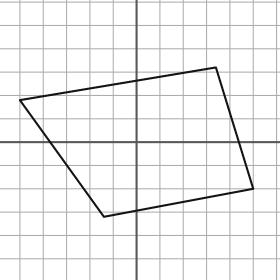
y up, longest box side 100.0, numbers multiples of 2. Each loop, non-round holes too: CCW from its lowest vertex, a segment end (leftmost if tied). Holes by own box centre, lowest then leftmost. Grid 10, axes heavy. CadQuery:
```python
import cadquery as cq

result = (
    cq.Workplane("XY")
    .moveTo(-14.0, -32.0)
    .lineTo(50.0, -20.0)
    .lineTo(34.0, 32.0)
    .lineTo(-50.0, 18.0)
    .close()
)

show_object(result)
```